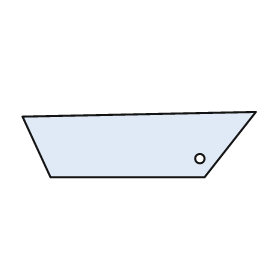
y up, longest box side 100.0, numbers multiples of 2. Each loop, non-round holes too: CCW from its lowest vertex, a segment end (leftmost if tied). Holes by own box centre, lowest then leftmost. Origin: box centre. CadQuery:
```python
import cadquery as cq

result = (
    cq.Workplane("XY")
    .moveTo(-38.0, -14.0)
    .lineTo(28.0, -14.0)
    .lineTo(50.0, 14.0)
    .lineTo(-50.0, 12.0)
    .close()
    .moveTo(26.0, -6.0)
    .circle(2.0)
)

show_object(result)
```